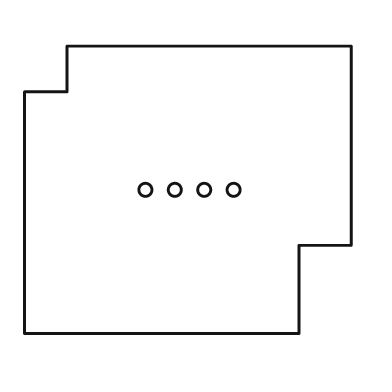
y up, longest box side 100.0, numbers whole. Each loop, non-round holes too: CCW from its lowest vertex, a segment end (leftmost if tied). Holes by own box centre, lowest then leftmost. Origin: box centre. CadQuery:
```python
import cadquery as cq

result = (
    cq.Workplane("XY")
    .moveTo(-50.0, -44.0)
    .lineTo(34.0, -44.0)
    .lineTo(34.0, -17.0)
    .lineTo(50.0, -17.0)
    .lineTo(50.0, 44.0)
    .lineTo(-37.0, 44.0)
    .lineTo(-37.0, 30.0)
    .lineTo(-50.0, 30.0)
    .close()
    .moveTo(-13.0, 0.0)
    .circle(2.0)
    .moveTo(-4.0, 0.0)
    .circle(2.0)
    .moveTo(5.0, 0.0)
    .circle(2.0)
    .moveTo(14.0, 0.0)
    .circle(2.0)
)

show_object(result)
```